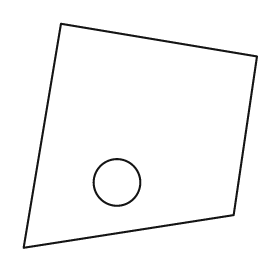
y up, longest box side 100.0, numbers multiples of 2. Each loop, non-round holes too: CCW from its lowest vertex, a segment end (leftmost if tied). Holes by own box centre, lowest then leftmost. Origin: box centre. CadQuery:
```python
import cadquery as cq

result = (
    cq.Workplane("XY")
    .moveTo(-50.0, -48.0)
    .lineTo(40.0, -34.0)
    .lineTo(50.0, 34.0)
    .lineTo(-34.0, 48.0)
    .close()
    .moveTo(-10.0, -20.0)
    .circle(10.0)
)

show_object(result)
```